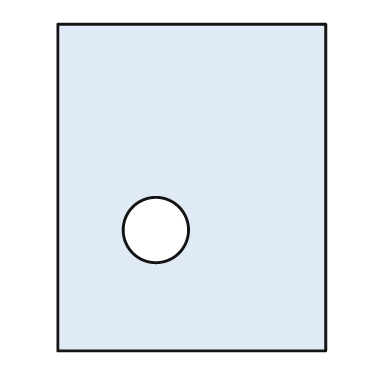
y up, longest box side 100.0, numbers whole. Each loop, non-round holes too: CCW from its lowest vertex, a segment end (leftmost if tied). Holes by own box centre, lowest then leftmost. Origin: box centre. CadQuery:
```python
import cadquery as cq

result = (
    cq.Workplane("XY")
    .moveTo(-41.0, -50.0)
    .lineTo(41.0, -50.0)
    .lineTo(41.0, 50.0)
    .lineTo(-41.0, 50.0)
    .close()
    .moveTo(-11.0, -13.0)
    .circle(10.0)
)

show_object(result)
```